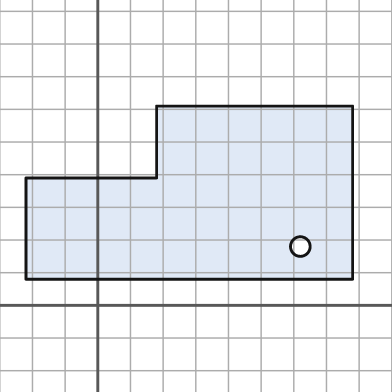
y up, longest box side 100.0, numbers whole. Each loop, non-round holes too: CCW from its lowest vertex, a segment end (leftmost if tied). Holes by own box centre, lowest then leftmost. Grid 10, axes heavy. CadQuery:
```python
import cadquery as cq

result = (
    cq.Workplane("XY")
    .moveTo(-22.0, 8.0)
    .lineTo(78.0, 8.0)
    .lineTo(78.0, 61.0)
    .lineTo(18.0, 61.0)
    .lineTo(18.0, 39.0)
    .lineTo(-22.0, 39.0)
    .close()
    .moveTo(62.0, 18.0)
    .circle(3.0)
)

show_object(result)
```